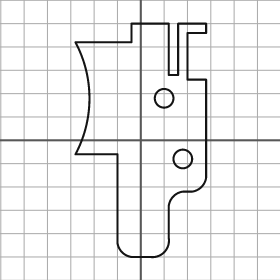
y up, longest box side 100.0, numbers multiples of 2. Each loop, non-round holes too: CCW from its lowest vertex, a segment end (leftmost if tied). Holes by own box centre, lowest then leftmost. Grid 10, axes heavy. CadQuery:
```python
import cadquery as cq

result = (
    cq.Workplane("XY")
    .moveTo(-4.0, -50.0)
    .lineTo(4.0, -50.0)
    .threePointArc((10.0, -48.0), (12.0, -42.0))
    .lineTo(12.0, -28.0)
    .threePointArc((14.0, -24.0), (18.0, -22.0))
    .lineTo(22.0, -22.0)
    .threePointArc((26.0, -20.0), (28.0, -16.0))
    .lineTo(28.0, 26.0)
    .lineTo(20.0, 26.0)
    .lineTo(20.0, 46.0)
    .lineTo(28.0, 46.0)
    .lineTo(28.0, 50.0)
    .lineTo(16.0, 50.0)
    .lineTo(16.0, 28.0)
    .lineTo(12.0, 28.0)
    .lineTo(12.0, 50.0)
    .lineTo(-4.0, 50.0)
    .lineTo(-4.0, 42.0)
    .lineTo(-28.0, 42.0)
    .threePointArc((-22.0, 18.0), (-28.0, -6.0))
    .lineTo(-10.0, -6.0)
    .lineTo(-10.0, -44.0)
    .threePointArc((-8.0, -48.0), (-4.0, -50.0))
    .close()
    .moveTo(18.0, -8.0)
    .circle(4.0)
    .moveTo(10.0, 18.0)
    .circle(4.0)
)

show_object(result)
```